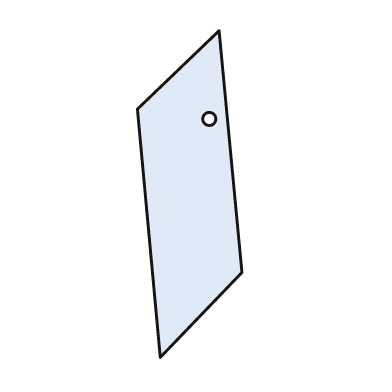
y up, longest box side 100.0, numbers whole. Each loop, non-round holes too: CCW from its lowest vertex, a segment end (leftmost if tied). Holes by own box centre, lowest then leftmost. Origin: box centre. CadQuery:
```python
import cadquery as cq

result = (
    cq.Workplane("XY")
    .moveTo(-9.0, -50.0)
    .lineTo(16.0, -24.0)
    .lineTo(9.0, 50.0)
    .lineTo(-16.0, 26.0)
    .close()
    .moveTo(6.0, 23.0)
    .circle(2.0)
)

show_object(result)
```